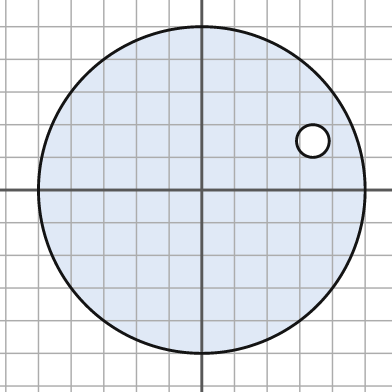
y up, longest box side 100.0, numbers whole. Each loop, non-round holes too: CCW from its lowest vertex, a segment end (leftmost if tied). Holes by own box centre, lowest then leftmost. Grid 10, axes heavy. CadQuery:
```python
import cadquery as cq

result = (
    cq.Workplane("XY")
    .moveTo(0.0, 0.0)
    .circle(50.0)
    .moveTo(34.0, 15.0)
    .circle(5.0)
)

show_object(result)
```